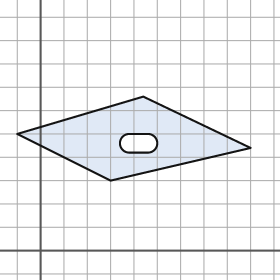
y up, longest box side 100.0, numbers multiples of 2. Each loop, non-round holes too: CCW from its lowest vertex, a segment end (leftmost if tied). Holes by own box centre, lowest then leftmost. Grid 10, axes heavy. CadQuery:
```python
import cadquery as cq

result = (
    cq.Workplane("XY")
    .moveTo(30.0, 30.0)
    .lineTo(90.0, 44.0)
    .lineTo(44.0, 66.0)
    .lineTo(-10.0, 50.0)
    .close()
    .moveTo(38.0, 42.0)
    .lineTo(46.0, 42.0)
    .threePointArc((50.0, 46.0), (46.0, 50.0))
    .lineTo(38.0, 50.0)
    .threePointArc((34.0, 46.0), (38.0, 42.0))
    .close()
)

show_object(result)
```